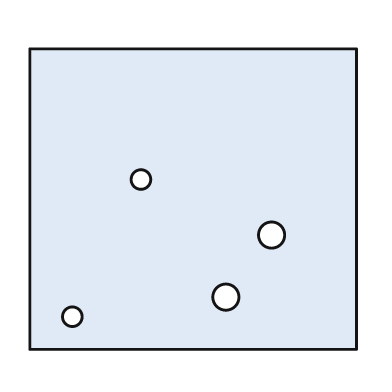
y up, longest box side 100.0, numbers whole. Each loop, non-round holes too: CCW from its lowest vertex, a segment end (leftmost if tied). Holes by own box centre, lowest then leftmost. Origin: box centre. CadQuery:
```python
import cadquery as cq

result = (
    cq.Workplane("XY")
    .moveTo(-50.0, -46.0)
    .lineTo(50.0, -46.0)
    .lineTo(50.0, 46.0)
    .lineTo(-50.0, 46.0)
    .close()
    .moveTo(-37.0, -36.0)
    .circle(3.0)
    .moveTo(10.0, -30.0)
    .circle(4.0)
    .moveTo(24.0, -11.0)
    .circle(4.0)
    .moveTo(-16.0, 6.0)
    .circle(3.0)
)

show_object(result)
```